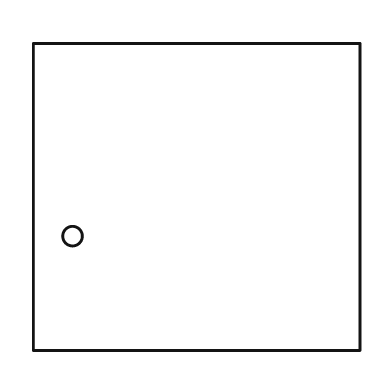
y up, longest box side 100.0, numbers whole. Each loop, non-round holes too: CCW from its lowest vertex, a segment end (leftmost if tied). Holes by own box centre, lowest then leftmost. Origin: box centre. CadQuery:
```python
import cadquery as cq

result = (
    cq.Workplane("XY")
    .moveTo(-50.0, -47.0)
    .lineTo(50.0, -47.0)
    .lineTo(50.0, 47.0)
    .lineTo(-50.0, 47.0)
    .close()
    .moveTo(-38.0, -12.0)
    .circle(3.0)
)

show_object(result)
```